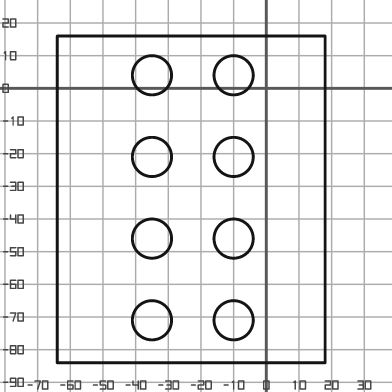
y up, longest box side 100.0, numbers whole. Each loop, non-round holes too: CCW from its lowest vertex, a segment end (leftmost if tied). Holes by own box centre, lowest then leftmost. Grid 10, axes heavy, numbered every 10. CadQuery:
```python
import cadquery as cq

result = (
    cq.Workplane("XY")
    .moveTo(-64.0, -84.0)
    .lineTo(18.0, -84.0)
    .lineTo(18.0, 16.0)
    .lineTo(-64.0, 16.0)
    .close()
    .moveTo(-35.0, -71.0)
    .circle(6.0)
    .moveTo(-10.0, -71.0)
    .circle(6.0)
    .moveTo(-35.0, -46.0)
    .circle(6.0)
    .moveTo(-10.0, -46.0)
    .circle(6.0)
    .moveTo(-35.0, -21.0)
    .circle(6.0)
    .moveTo(-10.0, -21.0)
    .circle(6.0)
    .moveTo(-35.0, 4.0)
    .circle(6.0)
    .moveTo(-10.0, 4.0)
    .circle(6.0)
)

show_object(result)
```